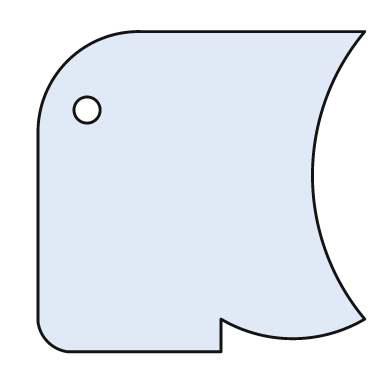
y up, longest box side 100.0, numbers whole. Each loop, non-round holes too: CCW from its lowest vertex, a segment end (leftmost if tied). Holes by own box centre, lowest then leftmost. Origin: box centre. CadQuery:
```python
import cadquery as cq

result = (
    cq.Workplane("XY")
    .moveTo(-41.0, -49.0)
    .lineTo(6.0, -49.0)
    .lineTo(6.0, -39.0)
    .threePointArc((28.0, -45.0), (50.0, -39.0))
    .threePointArc((34.0, 5.0), (50.0, 49.0))
    .lineTo(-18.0, 49.0)
    .threePointArc((-41.0, 40.0), (-50.0, 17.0))
    .lineTo(-50.0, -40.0)
    .threePointArc((-47.0, -46.0), (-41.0, -49.0))
    .close()
    .moveTo(-35.0, 25.0)
    .circle(4.0)
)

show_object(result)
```